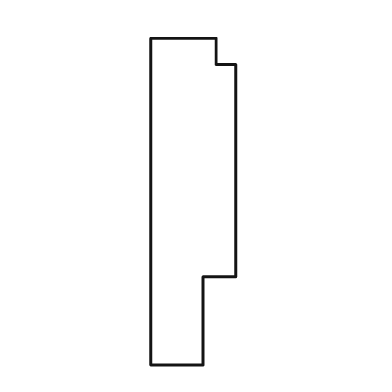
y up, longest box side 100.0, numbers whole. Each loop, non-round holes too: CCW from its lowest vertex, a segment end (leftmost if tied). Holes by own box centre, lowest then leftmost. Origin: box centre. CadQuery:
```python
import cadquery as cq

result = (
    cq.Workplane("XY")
    .moveTo(-13.0, -50.0)
    .lineTo(3.0, -50.0)
    .lineTo(3.0, -23.0)
    .lineTo(13.0, -23.0)
    .lineTo(13.0, 42.0)
    .lineTo(7.0, 42.0)
    .lineTo(7.0, 50.0)
    .lineTo(-13.0, 50.0)
    .close()
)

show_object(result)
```